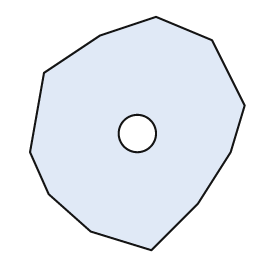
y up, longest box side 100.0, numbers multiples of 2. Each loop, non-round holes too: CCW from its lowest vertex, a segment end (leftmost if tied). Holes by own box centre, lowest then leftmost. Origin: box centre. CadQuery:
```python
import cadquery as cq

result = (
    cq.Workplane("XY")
    .moveTo(6.0, -50.0)
    .lineTo(26.0, -30.0)
    .lineTo(40.0, -8.0)
    .lineTo(46.0, 12.0)
    .lineTo(32.0, 40.0)
    .lineTo(8.0, 50.0)
    .lineTo(-16.0, 42.0)
    .lineTo(-40.0, 26.0)
    .lineTo(-46.0, -8.0)
    .lineTo(-38.0, -26.0)
    .lineTo(-20.0, -42.0)
    .close()
    .moveTo(0.0, 0.0)
    .circle(8.0)
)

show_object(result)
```